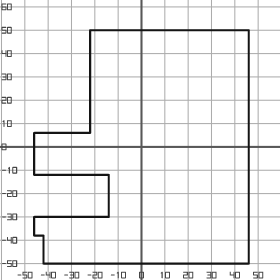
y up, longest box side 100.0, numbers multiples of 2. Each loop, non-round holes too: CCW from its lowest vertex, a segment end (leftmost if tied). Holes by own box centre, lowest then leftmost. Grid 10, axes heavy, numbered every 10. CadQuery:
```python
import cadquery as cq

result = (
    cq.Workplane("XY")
    .moveTo(-42.0, -50.0)
    .lineTo(46.0, -50.0)
    .lineTo(46.0, 50.0)
    .lineTo(-22.0, 50.0)
    .lineTo(-22.0, 6.0)
    .lineTo(-46.0, 6.0)
    .lineTo(-46.0, -12.0)
    .lineTo(-14.0, -12.0)
    .lineTo(-14.0, -30.0)
    .lineTo(-46.0, -30.0)
    .lineTo(-46.0, -38.0)
    .lineTo(-42.0, -38.0)
    .close()
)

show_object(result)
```